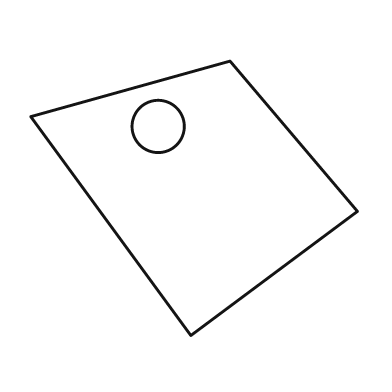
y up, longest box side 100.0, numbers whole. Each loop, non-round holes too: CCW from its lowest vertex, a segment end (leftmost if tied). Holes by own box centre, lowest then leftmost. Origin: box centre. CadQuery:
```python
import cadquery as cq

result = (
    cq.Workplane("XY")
    .moveTo(-1.0, -42.0)
    .lineTo(50.0, -4.0)
    .lineTo(11.0, 42.0)
    .lineTo(-50.0, 25.0)
    .close()
    .moveTo(-11.0, 22.0)
    .circle(8.0)
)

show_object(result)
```